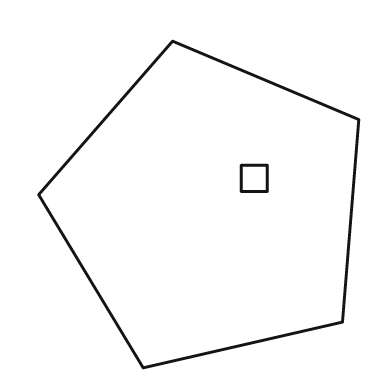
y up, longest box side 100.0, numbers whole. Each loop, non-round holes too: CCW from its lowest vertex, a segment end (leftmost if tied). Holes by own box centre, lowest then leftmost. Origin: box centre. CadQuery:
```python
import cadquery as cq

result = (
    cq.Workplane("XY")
    .moveTo(-17.0, -50.0)
    .lineTo(44.0, -36.0)
    .lineTo(49.0, 26.0)
    .lineTo(-8.0, 50.0)
    .lineTo(-49.0, 3.0)
    .close()
    .moveTo(13.0, 4.0)
    .lineTo(21.0, 4.0)
    .lineTo(21.0, 12.0)
    .lineTo(13.0, 12.0)
    .close()
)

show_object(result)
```